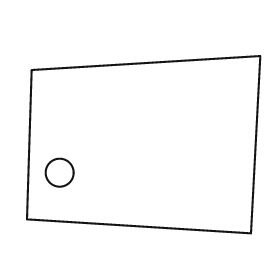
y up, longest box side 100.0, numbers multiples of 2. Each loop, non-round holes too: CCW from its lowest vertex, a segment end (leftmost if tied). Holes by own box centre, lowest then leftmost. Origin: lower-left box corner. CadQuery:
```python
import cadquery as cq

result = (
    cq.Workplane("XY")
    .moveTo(96.0, 0.0)
    .lineTo(100.0, 76.0)
    .lineTo(2.0, 70.0)
    .lineTo(0.0, 6.0)
    .close()
    .moveTo(14.0, 26.0)
    .circle(6.0)
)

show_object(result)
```